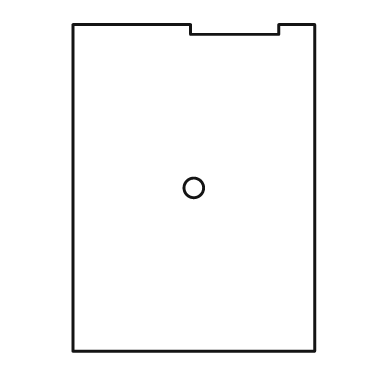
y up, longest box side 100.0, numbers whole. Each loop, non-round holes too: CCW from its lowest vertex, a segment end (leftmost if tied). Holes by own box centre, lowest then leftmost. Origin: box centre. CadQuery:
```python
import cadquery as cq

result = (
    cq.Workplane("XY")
    .moveTo(-37.0, -50.0)
    .lineTo(37.0, -50.0)
    .lineTo(37.0, 50.0)
    .lineTo(26.0, 50.0)
    .lineTo(26.0, 47.0)
    .lineTo(-1.0, 47.0)
    .lineTo(-1.0, 50.0)
    .lineTo(-37.0, 50.0)
    .close()
    .moveTo(0.0, 0.0)
    .circle(3.0)
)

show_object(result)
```